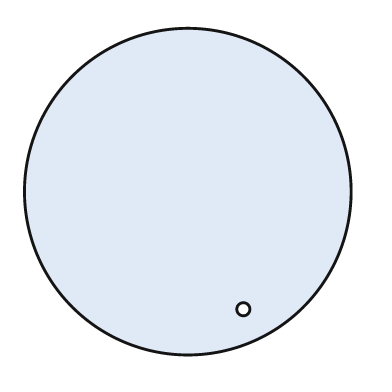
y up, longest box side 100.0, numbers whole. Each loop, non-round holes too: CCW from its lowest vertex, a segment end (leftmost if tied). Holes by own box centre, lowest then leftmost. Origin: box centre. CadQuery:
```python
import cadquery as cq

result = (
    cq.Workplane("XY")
    .moveTo(0.0, 0.0)
    .circle(50.0)
    .moveTo(17.0, -36.0)
    .circle(2.0)
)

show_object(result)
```